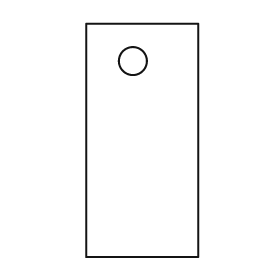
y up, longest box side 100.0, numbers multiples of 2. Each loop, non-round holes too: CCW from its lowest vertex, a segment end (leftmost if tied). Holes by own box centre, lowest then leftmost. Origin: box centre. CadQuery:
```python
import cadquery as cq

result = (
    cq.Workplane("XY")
    .moveTo(-24.0, -50.0)
    .lineTo(24.0, -50.0)
    .lineTo(24.0, 50.0)
    .lineTo(-24.0, 50.0)
    .close()
    .moveTo(-4.0, 34.0)
    .circle(6.0)
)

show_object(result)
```